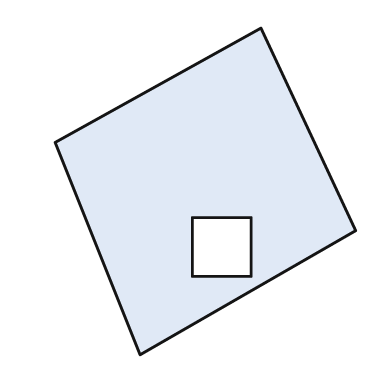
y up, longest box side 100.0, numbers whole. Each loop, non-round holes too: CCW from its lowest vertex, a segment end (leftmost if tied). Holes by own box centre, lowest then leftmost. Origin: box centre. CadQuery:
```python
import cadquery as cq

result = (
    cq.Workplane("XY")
    .moveTo(-20.0, -50.0)
    .lineTo(46.0, -12.0)
    .lineTo(17.0, 50.0)
    .lineTo(-46.0, 15.0)
    .close()
    .moveTo(-4.0, -26.0)
    .lineTo(14.0, -26.0)
    .lineTo(14.0, -8.0)
    .lineTo(-4.0, -8.0)
    .close()
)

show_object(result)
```